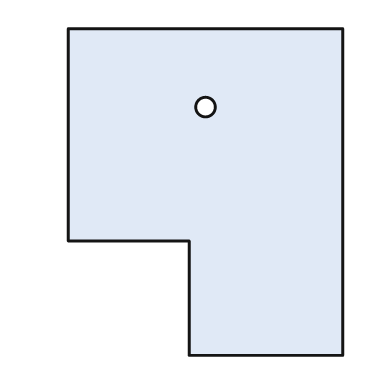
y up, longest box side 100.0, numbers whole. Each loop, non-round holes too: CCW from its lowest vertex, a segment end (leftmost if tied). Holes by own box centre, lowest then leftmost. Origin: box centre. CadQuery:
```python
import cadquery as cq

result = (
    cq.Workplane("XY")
    .moveTo(-5.0, -50.0)
    .lineTo(42.0, -50.0)
    .lineTo(42.0, 50.0)
    .lineTo(-42.0, 50.0)
    .lineTo(-42.0, -15.0)
    .lineTo(-5.0, -15.0)
    .close()
    .moveTo(0.0, 26.0)
    .circle(3.0)
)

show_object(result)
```